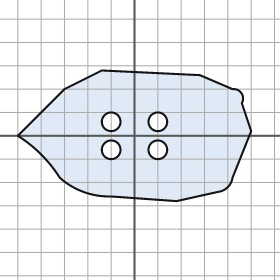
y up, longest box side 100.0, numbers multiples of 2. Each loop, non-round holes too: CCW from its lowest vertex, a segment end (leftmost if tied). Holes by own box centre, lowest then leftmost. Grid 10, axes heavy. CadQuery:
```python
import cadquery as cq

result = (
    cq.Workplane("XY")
    .moveTo(18.0, -28.0)
    .lineTo(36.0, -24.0)
    .threePointArc((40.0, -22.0), (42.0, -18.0))
    .lineTo(50.0, 2.0)
    .lineTo(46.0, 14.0)
    .threePointArc((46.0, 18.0), (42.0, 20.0))
    .lineTo(28.0, 26.0)
    .lineTo(-14.0, 28.0)
    .lineTo(-30.0, 20.0)
    .lineTo(-50.0, 0.0)
    .threePointArc((-40.0, -8.0), (-32.0, -18.0))
    .threePointArc((-22.0, -24.0), (-10.0, -26.0))
    .close()
    .moveTo(-10.0, -6.0)
    .circle(4.0)
    .moveTo(10.0, -6.0)
    .circle(4.0)
    .moveTo(-10.0, 6.0)
    .circle(4.0)
    .moveTo(10.0, 6.0)
    .circle(4.0)
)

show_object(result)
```